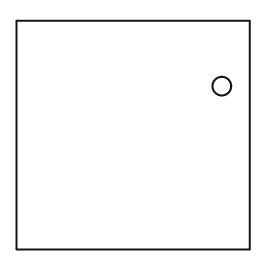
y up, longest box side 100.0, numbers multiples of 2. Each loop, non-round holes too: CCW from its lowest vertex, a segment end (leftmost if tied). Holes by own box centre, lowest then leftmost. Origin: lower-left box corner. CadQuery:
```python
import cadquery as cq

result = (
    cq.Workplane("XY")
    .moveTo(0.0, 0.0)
    .lineTo(100.0, 0.0)
    .lineTo(100.0, 98.0)
    .lineTo(0.0, 98.0)
    .close()
    .moveTo(88.0, 70.0)
    .circle(4.0)
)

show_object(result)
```